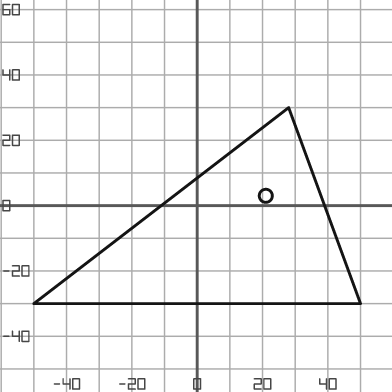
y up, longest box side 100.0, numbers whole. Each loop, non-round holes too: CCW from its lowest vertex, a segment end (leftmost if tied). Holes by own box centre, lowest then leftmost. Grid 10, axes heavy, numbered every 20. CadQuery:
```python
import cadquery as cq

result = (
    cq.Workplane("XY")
    .moveTo(-50.0, -30.0)
    .lineTo(50.0, -30.0)
    .lineTo(28.0, 30.0)
    .close()
    .moveTo(21.0, 3.0)
    .circle(2.0)
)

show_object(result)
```